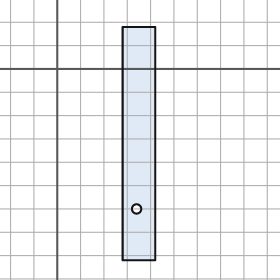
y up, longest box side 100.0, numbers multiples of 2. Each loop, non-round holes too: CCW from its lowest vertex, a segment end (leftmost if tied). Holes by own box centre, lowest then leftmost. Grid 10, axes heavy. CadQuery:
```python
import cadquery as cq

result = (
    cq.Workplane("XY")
    .moveTo(28.0, -82.0)
    .lineTo(42.0, -82.0)
    .lineTo(42.0, 18.0)
    .lineTo(28.0, 18.0)
    .close()
    .moveTo(34.0, -60.0)
    .circle(2.0)
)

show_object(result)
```